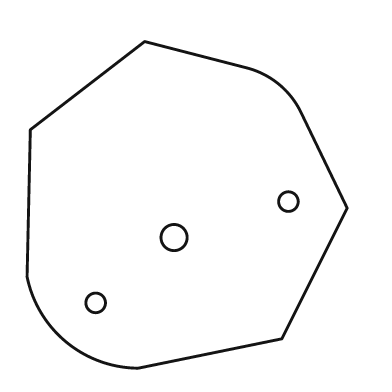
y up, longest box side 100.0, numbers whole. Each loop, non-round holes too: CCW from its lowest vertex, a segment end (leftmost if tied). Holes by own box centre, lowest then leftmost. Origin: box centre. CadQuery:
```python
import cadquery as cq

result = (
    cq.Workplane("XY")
    .moveTo(-15.0, -50.0)
    .lineTo(29.0, -41.0)
    .lineTo(49.0, -1.0)
    .lineTo(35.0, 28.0)
    .threePointArc((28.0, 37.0), (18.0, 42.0))
    .lineTo(-13.0, 50.0)
    .lineTo(-48.0, 23.0)
    .lineTo(-49.0, -22.0)
    .threePointArc((-37.0, -42.0), (-15.0, -50.0))
    .close()
    .moveTo(-28.0, -30.0)
    .circle(3.0)
    .moveTo(-4.0, -10.0)
    .circle(4.0)
    .moveTo(31.0, 1.0)
    .circle(3.0)
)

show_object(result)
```